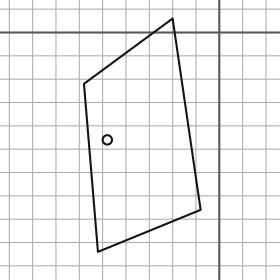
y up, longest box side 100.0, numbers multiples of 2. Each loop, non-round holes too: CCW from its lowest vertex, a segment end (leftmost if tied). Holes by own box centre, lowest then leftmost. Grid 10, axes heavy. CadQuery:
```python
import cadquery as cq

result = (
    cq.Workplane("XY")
    .moveTo(-52.0, -94.0)
    .lineTo(-8.0, -76.0)
    .lineTo(-20.0, 6.0)
    .lineTo(-58.0, -22.0)
    .close()
    .moveTo(-48.0, -46.0)
    .circle(2.0)
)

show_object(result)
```